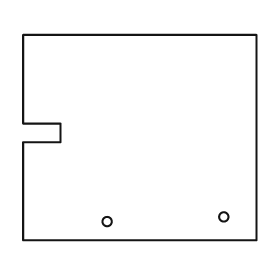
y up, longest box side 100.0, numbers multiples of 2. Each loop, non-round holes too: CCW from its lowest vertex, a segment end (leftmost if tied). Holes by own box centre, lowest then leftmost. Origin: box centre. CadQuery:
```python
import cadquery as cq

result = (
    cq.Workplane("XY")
    .moveTo(-50.0, -44.0)
    .lineTo(50.0, -44.0)
    .lineTo(50.0, 44.0)
    .lineTo(-50.0, 44.0)
    .lineTo(-50.0, 6.0)
    .lineTo(-34.0, 6.0)
    .lineTo(-34.0, -2.0)
    .lineTo(-50.0, -2.0)
    .close()
    .moveTo(-14.0, -36.0)
    .circle(2.0)
    .moveTo(36.0, -34.0)
    .circle(2.0)
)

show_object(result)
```